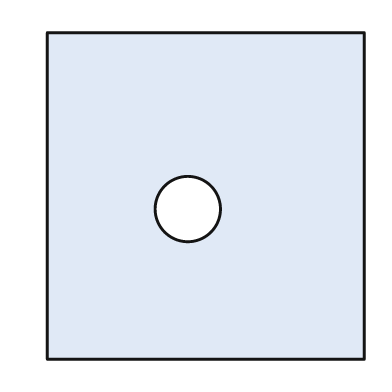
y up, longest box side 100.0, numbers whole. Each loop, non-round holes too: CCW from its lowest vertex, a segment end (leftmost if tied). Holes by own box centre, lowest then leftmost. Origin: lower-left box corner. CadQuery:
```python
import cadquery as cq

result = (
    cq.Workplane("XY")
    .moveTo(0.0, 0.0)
    .lineTo(97.0, 0.0)
    .lineTo(97.0, 100.0)
    .lineTo(0.0, 100.0)
    .close()
    .moveTo(43.0, 46.0)
    .circle(10.0)
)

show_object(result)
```